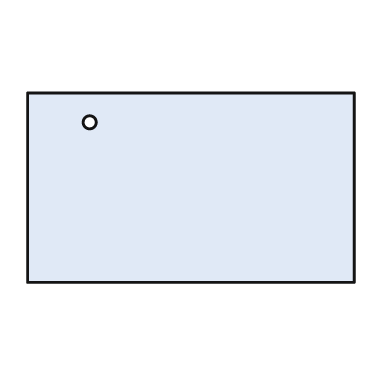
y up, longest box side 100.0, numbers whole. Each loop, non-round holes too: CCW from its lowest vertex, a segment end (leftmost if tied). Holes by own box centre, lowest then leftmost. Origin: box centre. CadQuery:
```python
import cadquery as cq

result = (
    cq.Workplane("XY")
    .moveTo(-50.0, -29.0)
    .lineTo(50.0, -29.0)
    .lineTo(50.0, 29.0)
    .lineTo(-50.0, 29.0)
    .close()
    .moveTo(-31.0, 20.0)
    .circle(2.0)
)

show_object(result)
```